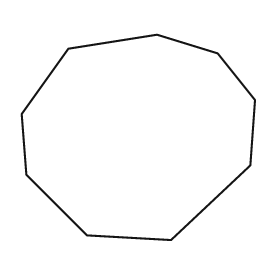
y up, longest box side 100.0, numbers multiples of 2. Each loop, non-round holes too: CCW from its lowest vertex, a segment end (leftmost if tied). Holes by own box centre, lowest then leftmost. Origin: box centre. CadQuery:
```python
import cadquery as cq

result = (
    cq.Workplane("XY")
    .moveTo(14.0, -44.0)
    .lineTo(48.0, -12.0)
    .lineTo(50.0, 16.0)
    .lineTo(34.0, 36.0)
    .lineTo(8.0, 44.0)
    .lineTo(-30.0, 38.0)
    .lineTo(-50.0, 10.0)
    .lineTo(-48.0, -16.0)
    .lineTo(-22.0, -42.0)
    .close()
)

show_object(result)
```